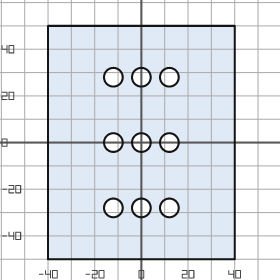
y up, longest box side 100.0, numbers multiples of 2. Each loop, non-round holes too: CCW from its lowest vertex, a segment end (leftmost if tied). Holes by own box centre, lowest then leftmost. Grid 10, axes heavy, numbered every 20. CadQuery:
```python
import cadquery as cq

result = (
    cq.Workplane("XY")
    .moveTo(-40.0, -50.0)
    .lineTo(40.0, -50.0)
    .lineTo(40.0, 50.0)
    .lineTo(-40.0, 50.0)
    .close()
    .moveTo(-12.0, -28.0)
    .circle(4.0)
    .moveTo(0.0, -28.0)
    .circle(4.0)
    .moveTo(12.0, -28.0)
    .circle(4.0)
    .moveTo(-12.0, 0.0)
    .circle(4.0)
    .moveTo(0.0, 0.0)
    .circle(4.0)
    .moveTo(12.0, 0.0)
    .circle(4.0)
    .moveTo(-12.0, 28.0)
    .circle(4.0)
    .moveTo(0.0, 28.0)
    .circle(4.0)
    .moveTo(12.0, 28.0)
    .circle(4.0)
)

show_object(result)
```